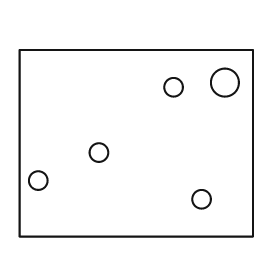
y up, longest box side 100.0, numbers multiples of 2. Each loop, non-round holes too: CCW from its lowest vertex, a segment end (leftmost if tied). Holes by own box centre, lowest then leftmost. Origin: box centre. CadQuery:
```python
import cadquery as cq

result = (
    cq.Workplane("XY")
    .moveTo(-50.0, -40.0)
    .lineTo(50.0, -40.0)
    .lineTo(50.0, 40.0)
    .lineTo(-50.0, 40.0)
    .close()
    .moveTo(28.0, -24.0)
    .circle(4.0)
    .moveTo(-42.0, -16.0)
    .circle(4.0)
    .moveTo(-16.0, -4.0)
    .circle(4.0)
    .moveTo(16.0, 24.0)
    .circle(4.0)
    .moveTo(38.0, 26.0)
    .circle(6.0)
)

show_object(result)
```